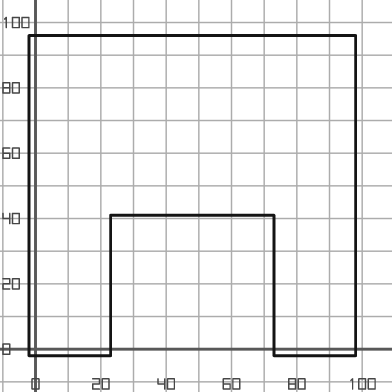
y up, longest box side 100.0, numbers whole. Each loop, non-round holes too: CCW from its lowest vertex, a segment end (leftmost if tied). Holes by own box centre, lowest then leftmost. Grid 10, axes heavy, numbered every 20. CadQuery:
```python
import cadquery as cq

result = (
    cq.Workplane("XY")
    .moveTo(-2.0, -2.0)
    .lineTo(23.0, -2.0)
    .lineTo(23.0, 41.0)
    .lineTo(73.0, 41.0)
    .lineTo(73.0, -2.0)
    .lineTo(98.0, -2.0)
    .lineTo(98.0, 96.0)
    .lineTo(-2.0, 96.0)
    .close()
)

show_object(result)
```